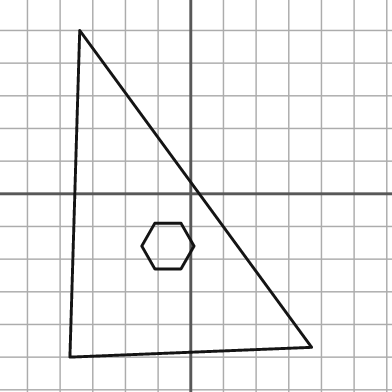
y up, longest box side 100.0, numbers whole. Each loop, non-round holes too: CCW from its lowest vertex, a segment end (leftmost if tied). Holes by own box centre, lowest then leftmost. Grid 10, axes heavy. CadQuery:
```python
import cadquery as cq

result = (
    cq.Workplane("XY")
    .moveTo(-37.0, -50.0)
    .lineTo(37.0, -47.0)
    .lineTo(-34.0, 50.0)
    .close()
    .moveTo(-11.0, -23.0)
    .lineTo(-3.0, -23.0)
    .lineTo(1.0, -16.0)
    .lineTo(-3.0, -9.0)
    .lineTo(-11.0, -9.0)
    .lineTo(-15.0, -16.0)
    .close()
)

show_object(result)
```